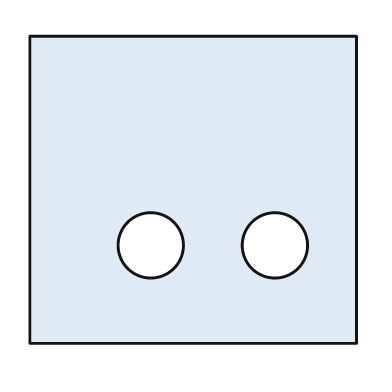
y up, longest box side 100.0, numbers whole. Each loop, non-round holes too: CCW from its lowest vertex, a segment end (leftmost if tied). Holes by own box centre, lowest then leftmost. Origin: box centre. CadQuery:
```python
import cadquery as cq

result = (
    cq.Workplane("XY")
    .moveTo(-50.0, -47.0)
    .lineTo(50.0, -47.0)
    .lineTo(50.0, 47.0)
    .lineTo(-50.0, 47.0)
    .close()
    .moveTo(-13.0, -17.0)
    .circle(10.0)
    .moveTo(25.0, -17.0)
    .circle(10.0)
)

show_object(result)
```